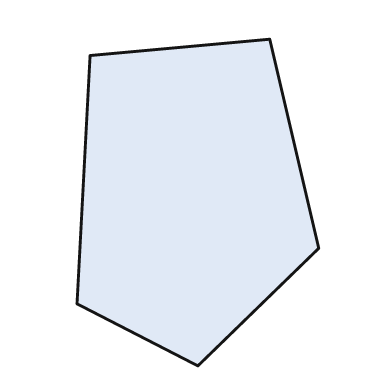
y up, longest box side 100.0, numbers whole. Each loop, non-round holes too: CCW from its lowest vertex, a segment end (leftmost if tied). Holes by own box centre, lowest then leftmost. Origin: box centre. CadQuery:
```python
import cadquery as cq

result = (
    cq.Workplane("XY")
    .moveTo(0.0, -50.0)
    .lineTo(37.0, -14.0)
    .lineTo(22.0, 50.0)
    .lineTo(-33.0, 45.0)
    .lineTo(-37.0, -31.0)
    .close()
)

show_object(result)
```